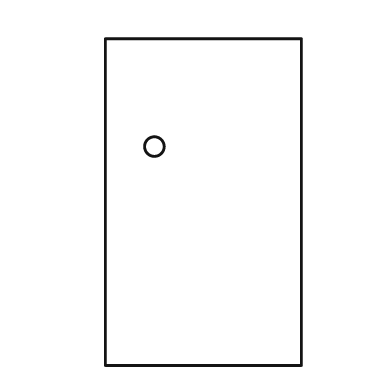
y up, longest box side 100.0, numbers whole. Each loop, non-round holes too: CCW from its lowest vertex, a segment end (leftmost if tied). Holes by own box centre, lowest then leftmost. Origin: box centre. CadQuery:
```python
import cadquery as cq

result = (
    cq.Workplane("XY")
    .moveTo(-30.0, -50.0)
    .lineTo(30.0, -50.0)
    .lineTo(30.0, 50.0)
    .lineTo(-30.0, 50.0)
    .close()
    .moveTo(-15.0, 17.0)
    .circle(3.0)
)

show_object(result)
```